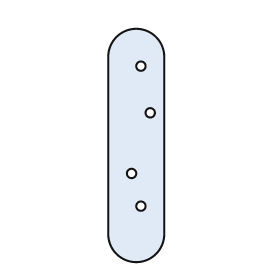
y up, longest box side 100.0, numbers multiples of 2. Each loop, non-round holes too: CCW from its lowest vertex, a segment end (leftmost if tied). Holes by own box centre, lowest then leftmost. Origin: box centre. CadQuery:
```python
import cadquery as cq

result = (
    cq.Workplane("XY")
    .moveTo(-12.0, -38.0)
    .threePointArc((0.0, -50.0), (12.0, -38.0))
    .lineTo(12.0, 38.0)
    .threePointArc((0.0, 50.0), (-12.0, 38.0))
    .close()
    .moveTo(2.0, -26.0)
    .circle(2.0)
    .moveTo(-2.0, -12.0)
    .circle(2.0)
    .moveTo(6.0, 14.0)
    .circle(2.0)
    .moveTo(2.0, 34.0)
    .circle(2.0)
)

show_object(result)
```